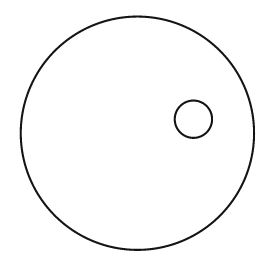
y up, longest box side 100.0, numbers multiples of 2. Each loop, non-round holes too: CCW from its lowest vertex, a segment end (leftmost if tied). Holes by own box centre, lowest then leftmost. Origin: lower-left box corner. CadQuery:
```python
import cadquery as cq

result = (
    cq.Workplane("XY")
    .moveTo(50.0, 50.0)
    .circle(50.0)
    .moveTo(74.0, 56.0)
    .circle(8.0)
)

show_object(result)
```